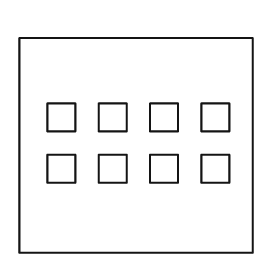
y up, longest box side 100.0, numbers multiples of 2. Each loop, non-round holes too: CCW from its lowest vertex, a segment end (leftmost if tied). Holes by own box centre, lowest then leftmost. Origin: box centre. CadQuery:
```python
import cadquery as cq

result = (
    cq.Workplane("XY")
    .moveTo(-50.0, -46.0)
    .lineTo(50.0, -46.0)
    .lineTo(50.0, 46.0)
    .lineTo(-50.0, 46.0)
    .close()
    .moveTo(-38.0, -16.0)
    .lineTo(-26.0, -16.0)
    .lineTo(-26.0, -4.0)
    .lineTo(-38.0, -4.0)
    .close()
    .moveTo(-16.0, -16.0)
    .lineTo(-4.0, -16.0)
    .lineTo(-4.0, -4.0)
    .lineTo(-16.0, -4.0)
    .close()
    .moveTo(6.0, -16.0)
    .lineTo(18.0, -16.0)
    .lineTo(18.0, -4.0)
    .lineTo(6.0, -4.0)
    .close()
    .moveTo(28.0, -16.0)
    .lineTo(40.0, -16.0)
    .lineTo(40.0, -4.0)
    .lineTo(28.0, -4.0)
    .close()
    .moveTo(-38.0, 6.0)
    .lineTo(-26.0, 6.0)
    .lineTo(-26.0, 18.0)
    .lineTo(-38.0, 18.0)
    .close()
    .moveTo(-16.0, 6.0)
    .lineTo(-4.0, 6.0)
    .lineTo(-4.0, 18.0)
    .lineTo(-16.0, 18.0)
    .close()
    .moveTo(6.0, 6.0)
    .lineTo(18.0, 6.0)
    .lineTo(18.0, 18.0)
    .lineTo(6.0, 18.0)
    .close()
    .moveTo(28.0, 6.0)
    .lineTo(40.0, 6.0)
    .lineTo(40.0, 18.0)
    .lineTo(28.0, 18.0)
    .close()
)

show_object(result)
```